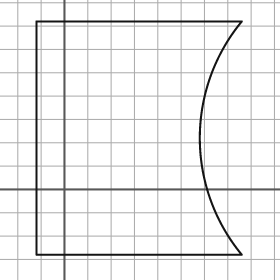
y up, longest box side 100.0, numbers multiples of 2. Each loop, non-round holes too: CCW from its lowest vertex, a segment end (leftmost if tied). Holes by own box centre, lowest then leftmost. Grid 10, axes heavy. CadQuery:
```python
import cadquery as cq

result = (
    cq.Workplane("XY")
    .moveTo(-12.0, -28.0)
    .lineTo(76.0, -28.0)
    .threePointArc((58.0, 22.0), (76.0, 72.0))
    .lineTo(-12.0, 72.0)
    .close()
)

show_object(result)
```